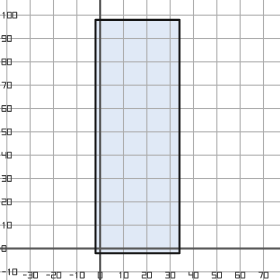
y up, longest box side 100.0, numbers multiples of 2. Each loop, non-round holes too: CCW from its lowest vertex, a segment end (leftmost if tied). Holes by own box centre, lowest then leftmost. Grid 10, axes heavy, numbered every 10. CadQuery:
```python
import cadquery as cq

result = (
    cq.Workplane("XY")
    .moveTo(-2.0, -2.0)
    .lineTo(34.0, -2.0)
    .lineTo(34.0, 98.0)
    .lineTo(-2.0, 98.0)
    .close()
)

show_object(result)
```